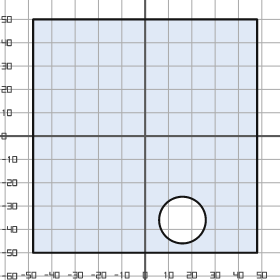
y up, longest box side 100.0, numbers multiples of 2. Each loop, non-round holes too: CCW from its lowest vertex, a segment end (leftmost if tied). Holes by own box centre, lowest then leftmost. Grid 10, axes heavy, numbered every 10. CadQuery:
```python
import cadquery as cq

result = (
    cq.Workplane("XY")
    .moveTo(-48.0, -50.0)
    .lineTo(48.0, -50.0)
    .lineTo(48.0, 50.0)
    .lineTo(-48.0, 50.0)
    .close()
    .moveTo(16.0, -36.0)
    .circle(10.0)
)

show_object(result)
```